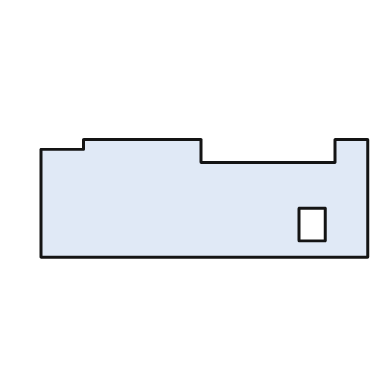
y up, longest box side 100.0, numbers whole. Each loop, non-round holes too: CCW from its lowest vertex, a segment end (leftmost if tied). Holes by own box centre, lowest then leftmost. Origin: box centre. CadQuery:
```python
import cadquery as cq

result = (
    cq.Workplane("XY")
    .moveTo(-50.0, -18.0)
    .lineTo(50.0, -18.0)
    .lineTo(50.0, 18.0)
    .lineTo(40.0, 18.0)
    .lineTo(40.0, 11.0)
    .lineTo(-1.0, 11.0)
    .lineTo(-1.0, 18.0)
    .lineTo(-37.0, 18.0)
    .lineTo(-37.0, 15.0)
    .lineTo(-50.0, 15.0)
    .close()
    .moveTo(29.0, -13.0)
    .lineTo(37.0, -13.0)
    .lineTo(37.0, -3.0)
    .lineTo(29.0, -3.0)
    .close()
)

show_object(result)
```